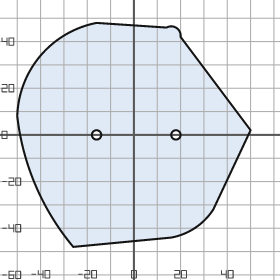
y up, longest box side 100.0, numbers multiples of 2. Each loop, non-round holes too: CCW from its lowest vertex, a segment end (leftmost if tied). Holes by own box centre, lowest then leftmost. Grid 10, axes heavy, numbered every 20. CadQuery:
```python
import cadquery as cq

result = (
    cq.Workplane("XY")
    .moveTo(-26.0, -48.0)
    .lineTo(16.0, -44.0)
    .threePointArc((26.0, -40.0), (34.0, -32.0))
    .lineTo(50.0, 2.0)
    .lineTo(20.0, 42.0)
    .threePointArc((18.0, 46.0), (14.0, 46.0))
    .lineTo(-16.0, 48.0)
    .threePointArc((-40.0, 34.0), (-50.0, 8.0))
    .threePointArc((-42.0, -22.0), (-26.0, -48.0))
    .close()
    .moveTo(-16.0, 0.0)
    .circle(2.0)
    .moveTo(18.0, 0.0)
    .circle(2.0)
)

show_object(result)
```